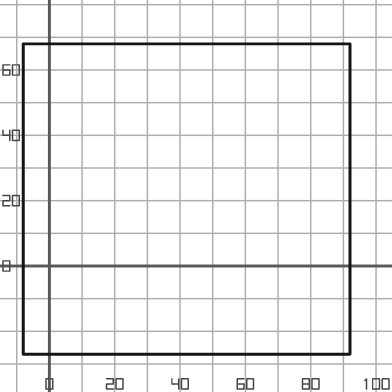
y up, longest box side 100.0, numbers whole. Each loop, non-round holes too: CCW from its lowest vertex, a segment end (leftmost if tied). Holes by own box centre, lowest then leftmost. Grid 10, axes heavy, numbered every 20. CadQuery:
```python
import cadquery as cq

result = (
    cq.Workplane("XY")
    .moveTo(-8.0, -27.0)
    .lineTo(92.0, -27.0)
    .lineTo(92.0, 68.0)
    .lineTo(-8.0, 68.0)
    .close()
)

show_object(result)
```